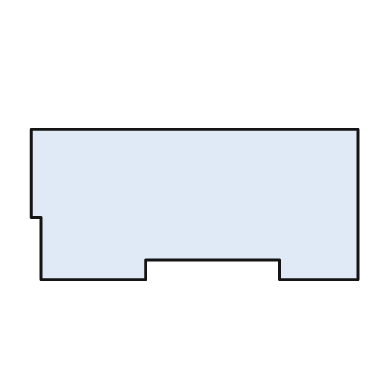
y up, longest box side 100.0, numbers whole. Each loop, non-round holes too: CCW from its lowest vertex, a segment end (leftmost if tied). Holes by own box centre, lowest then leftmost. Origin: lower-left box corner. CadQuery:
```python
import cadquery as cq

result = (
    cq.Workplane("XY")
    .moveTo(3.0, 0.0)
    .lineTo(35.0, 0.0)
    .lineTo(35.0, 6.0)
    .lineTo(76.0, 6.0)
    .lineTo(76.0, 0.0)
    .lineTo(100.0, 0.0)
    .lineTo(100.0, 46.0)
    .lineTo(0.0, 46.0)
    .lineTo(0.0, 19.0)
    .lineTo(3.0, 19.0)
    .close()
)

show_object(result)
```